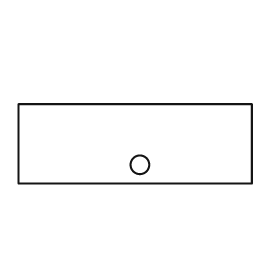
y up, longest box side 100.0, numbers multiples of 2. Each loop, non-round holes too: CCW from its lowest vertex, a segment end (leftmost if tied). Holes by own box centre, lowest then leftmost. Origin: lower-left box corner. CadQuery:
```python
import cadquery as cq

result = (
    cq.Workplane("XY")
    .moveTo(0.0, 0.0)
    .lineTo(100.0, 0.0)
    .lineTo(100.0, 34.0)
    .lineTo(0.0, 34.0)
    .close()
    .moveTo(52.0, 8.0)
    .circle(4.0)
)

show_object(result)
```